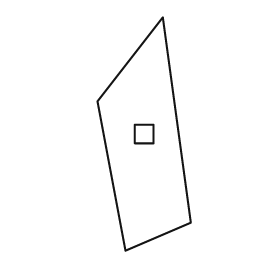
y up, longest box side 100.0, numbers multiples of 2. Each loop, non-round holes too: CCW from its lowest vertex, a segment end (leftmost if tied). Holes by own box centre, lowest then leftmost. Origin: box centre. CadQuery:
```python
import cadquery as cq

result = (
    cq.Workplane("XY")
    .moveTo(-8.0, -50.0)
    .lineTo(20.0, -38.0)
    .lineTo(8.0, 50.0)
    .lineTo(-20.0, 14.0)
    .close()
    .moveTo(-4.0, -4.0)
    .lineTo(4.0, -4.0)
    .lineTo(4.0, 4.0)
    .lineTo(-4.0, 4.0)
    .close()
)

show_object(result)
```